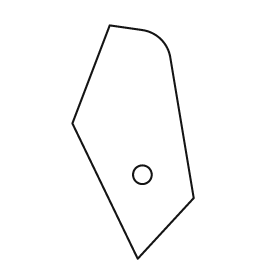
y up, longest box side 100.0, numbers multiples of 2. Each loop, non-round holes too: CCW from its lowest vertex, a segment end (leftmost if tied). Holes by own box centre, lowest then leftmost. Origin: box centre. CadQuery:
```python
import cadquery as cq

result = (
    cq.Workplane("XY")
    .moveTo(2.0, -50.0)
    .lineTo(26.0, -24.0)
    .lineTo(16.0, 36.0)
    .threePointArc((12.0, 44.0), (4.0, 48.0))
    .lineTo(-10.0, 50.0)
    .lineTo(-26.0, 8.0)
    .close()
    .moveTo(4.0, -14.0)
    .circle(4.0)
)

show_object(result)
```